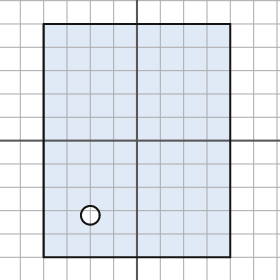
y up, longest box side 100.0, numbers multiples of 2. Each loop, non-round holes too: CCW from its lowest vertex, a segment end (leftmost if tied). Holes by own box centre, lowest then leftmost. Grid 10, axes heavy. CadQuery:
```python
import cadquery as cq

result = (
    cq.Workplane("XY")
    .moveTo(-40.0, -50.0)
    .lineTo(40.0, -50.0)
    .lineTo(40.0, 50.0)
    .lineTo(-40.0, 50.0)
    .close()
    .moveTo(-20.0, -32.0)
    .circle(4.0)
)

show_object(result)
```